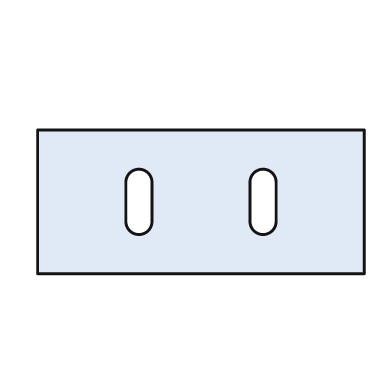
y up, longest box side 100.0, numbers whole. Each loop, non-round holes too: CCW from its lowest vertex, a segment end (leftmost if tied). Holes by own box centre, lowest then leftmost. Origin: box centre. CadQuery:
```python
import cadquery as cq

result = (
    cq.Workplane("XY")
    .moveTo(-50.0, -22.0)
    .lineTo(50.0, -22.0)
    .lineTo(50.0, 22.0)
    .lineTo(-50.0, 22.0)
    .close()
    .moveTo(-23.0, -6.0)
    .threePointArc((-19.0, -10.0), (-15.0, -6.0))
    .lineTo(-15.0, 6.0)
    .threePointArc((-19.0, 10.0), (-23.0, 6.0))
    .close()
    .moveTo(15.0, -6.0)
    .threePointArc((19.0, -10.0), (23.0, -6.0))
    .lineTo(23.0, 6.0)
    .threePointArc((19.0, 10.0), (15.0, 6.0))
    .close()
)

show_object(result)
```